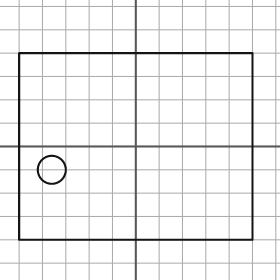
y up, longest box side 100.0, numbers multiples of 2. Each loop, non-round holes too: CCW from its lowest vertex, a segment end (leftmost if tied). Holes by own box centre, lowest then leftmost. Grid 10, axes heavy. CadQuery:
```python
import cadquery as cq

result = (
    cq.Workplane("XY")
    .moveTo(-50.0, -40.0)
    .lineTo(50.0, -40.0)
    .lineTo(50.0, 40.0)
    .lineTo(-50.0, 40.0)
    .close()
    .moveTo(-36.0, -10.0)
    .circle(6.0)
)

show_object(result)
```